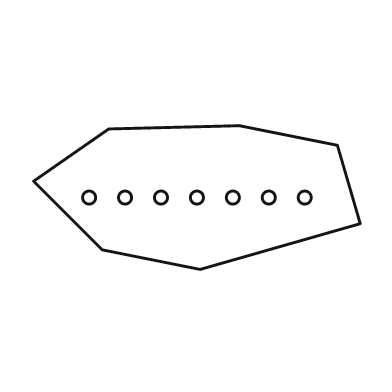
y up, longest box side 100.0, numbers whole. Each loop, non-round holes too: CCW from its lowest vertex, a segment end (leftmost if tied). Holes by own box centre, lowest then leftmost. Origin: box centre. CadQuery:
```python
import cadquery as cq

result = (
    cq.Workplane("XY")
    .moveTo(1.0, -22.0)
    .lineTo(50.0, -8.0)
    .lineTo(43.0, 16.0)
    .lineTo(13.0, 22.0)
    .lineTo(-27.0, 21.0)
    .lineTo(-50.0, 5.0)
    .lineTo(-29.0, -16.0)
    .close()
    .moveTo(-33.0, 0.0)
    .circle(2.0)
    .moveTo(-22.0, 0.0)
    .circle(2.0)
    .moveTo(-11.0, 0.0)
    .circle(2.0)
    .moveTo(0.0, 0.0)
    .circle(2.0)
    .moveTo(11.0, 0.0)
    .circle(2.0)
    .moveTo(22.0, 0.0)
    .circle(2.0)
    .moveTo(33.0, 0.0)
    .circle(2.0)
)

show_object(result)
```